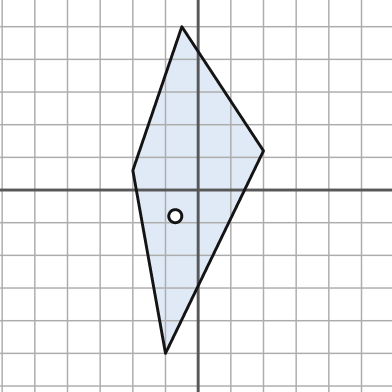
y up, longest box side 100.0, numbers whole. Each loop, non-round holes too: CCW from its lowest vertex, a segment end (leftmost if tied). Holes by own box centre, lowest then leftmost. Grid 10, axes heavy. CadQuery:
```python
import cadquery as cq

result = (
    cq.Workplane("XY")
    .moveTo(-10.0, -50.0)
    .lineTo(20.0, 12.0)
    .lineTo(-5.0, 50.0)
    .lineTo(-20.0, 6.0)
    .close()
    .moveTo(-7.0, -8.0)
    .circle(2.0)
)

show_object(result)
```